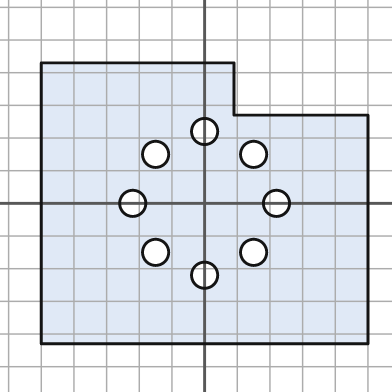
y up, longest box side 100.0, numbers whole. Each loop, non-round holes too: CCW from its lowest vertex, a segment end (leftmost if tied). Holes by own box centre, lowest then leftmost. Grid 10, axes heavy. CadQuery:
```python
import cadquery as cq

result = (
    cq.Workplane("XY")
    .moveTo(-50.0, -43.0)
    .lineTo(50.0, -43.0)
    .lineTo(50.0, 27.0)
    .lineTo(9.0, 27.0)
    .lineTo(9.0, 43.0)
    .lineTo(-50.0, 43.0)
    .close()
    .moveTo(0.0, -22.0)
    .circle(4.0)
    .moveTo(-15.0, -15.0)
    .circle(4.0)
    .moveTo(15.0, -15.0)
    .circle(4.0)
    .moveTo(-22.0, 0.0)
    .circle(4.0)
    .moveTo(22.0, 0.0)
    .circle(4.0)
    .moveTo(-15.0, 15.0)
    .circle(4.0)
    .moveTo(15.0, 15.0)
    .circle(4.0)
    .moveTo(0.0, 22.0)
    .circle(4.0)
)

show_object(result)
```